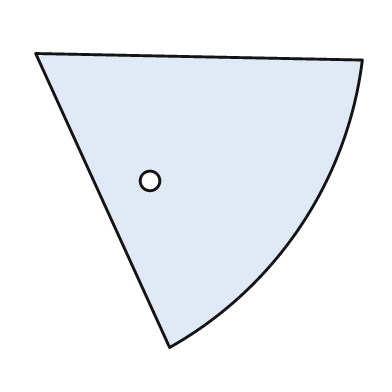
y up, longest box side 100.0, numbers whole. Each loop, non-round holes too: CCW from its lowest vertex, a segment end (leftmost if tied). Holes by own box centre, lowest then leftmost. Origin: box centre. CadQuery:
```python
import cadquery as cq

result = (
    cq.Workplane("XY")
    .moveTo(-9.0, -45.0)
    .threePointArc((31.0, -8.0), (50.0, 43.0))
    .lineTo(-50.0, 45.0)
    .close()
    .moveTo(-15.0, 6.0)
    .circle(3.0)
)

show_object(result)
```